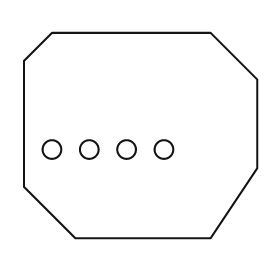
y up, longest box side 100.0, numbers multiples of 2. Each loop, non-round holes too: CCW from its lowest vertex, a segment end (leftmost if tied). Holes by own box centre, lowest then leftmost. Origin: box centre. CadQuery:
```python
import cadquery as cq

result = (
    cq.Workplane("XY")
    .moveTo(-28.0, -44.0)
    .lineTo(30.0, -44.0)
    .lineTo(50.0, -14.0)
    .lineTo(50.0, 24.0)
    .lineTo(30.0, 44.0)
    .lineTo(-38.0, 44.0)
    .lineTo(-50.0, 32.0)
    .lineTo(-50.0, -22.0)
    .close()
    .moveTo(-38.0, -6.0)
    .circle(4.0)
    .moveTo(-22.0, -6.0)
    .circle(4.0)
    .moveTo(-6.0, -6.0)
    .circle(4.0)
    .moveTo(10.0, -6.0)
    .circle(4.0)
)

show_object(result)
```